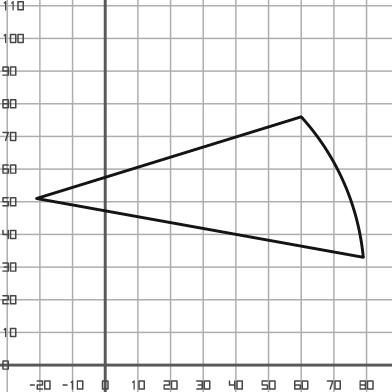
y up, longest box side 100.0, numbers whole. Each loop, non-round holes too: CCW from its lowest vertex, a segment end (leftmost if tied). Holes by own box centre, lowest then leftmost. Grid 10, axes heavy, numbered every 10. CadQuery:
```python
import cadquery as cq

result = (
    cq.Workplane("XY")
    .moveTo(79.0, 33.0)
    .threePointArc((73.0, 56.0), (60.0, 76.0))
    .lineTo(-21.0, 51.0)
    .close()
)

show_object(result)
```